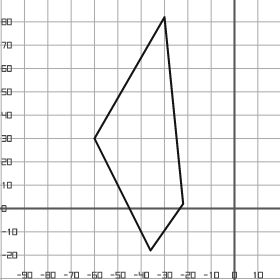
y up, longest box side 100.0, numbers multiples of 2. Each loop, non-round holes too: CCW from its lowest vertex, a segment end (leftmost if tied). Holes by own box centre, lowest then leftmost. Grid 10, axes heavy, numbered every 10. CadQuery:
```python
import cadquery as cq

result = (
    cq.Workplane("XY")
    .moveTo(-36.0, -18.0)
    .lineTo(-22.0, 2.0)
    .lineTo(-30.0, 82.0)
    .lineTo(-60.0, 30.0)
    .close()
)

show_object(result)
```